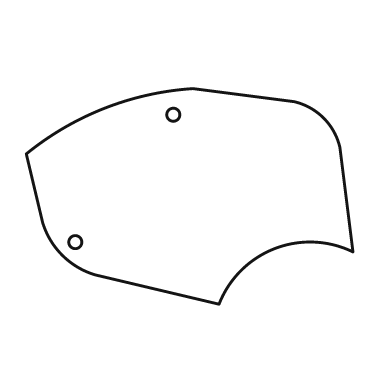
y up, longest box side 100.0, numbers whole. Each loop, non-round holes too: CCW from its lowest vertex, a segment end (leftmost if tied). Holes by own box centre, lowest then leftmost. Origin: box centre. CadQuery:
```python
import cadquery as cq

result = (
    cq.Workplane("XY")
    .moveTo(9.0, -33.0)
    .threePointArc((26.0, -16.0), (50.0, -17.0))
    .lineTo(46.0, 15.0)
    .threePointArc((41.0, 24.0), (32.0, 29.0))
    .lineTo(1.0, 33.0)
    .threePointArc((-26.0, 27.0), (-50.0, 13.0))
    .lineTo(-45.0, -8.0)
    .threePointArc((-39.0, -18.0), (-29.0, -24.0))
    .close()
    .moveTo(-35.0, -14.0)
    .circle(2.0)
    .moveTo(-5.0, 25.0)
    .circle(2.0)
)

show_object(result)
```